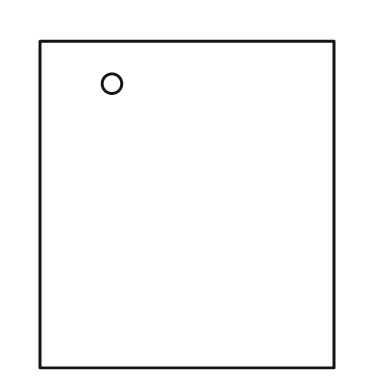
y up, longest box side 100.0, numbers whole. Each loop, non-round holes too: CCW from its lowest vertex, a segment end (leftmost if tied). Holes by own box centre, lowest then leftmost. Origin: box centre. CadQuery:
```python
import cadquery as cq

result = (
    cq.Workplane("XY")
    .moveTo(-45.0, -50.0)
    .lineTo(45.0, -50.0)
    .lineTo(45.0, 50.0)
    .lineTo(-45.0, 50.0)
    .close()
    .moveTo(-23.0, 37.0)
    .circle(3.0)
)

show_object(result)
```